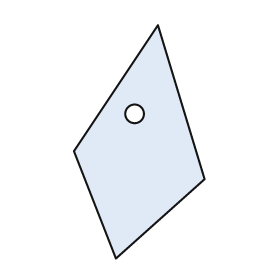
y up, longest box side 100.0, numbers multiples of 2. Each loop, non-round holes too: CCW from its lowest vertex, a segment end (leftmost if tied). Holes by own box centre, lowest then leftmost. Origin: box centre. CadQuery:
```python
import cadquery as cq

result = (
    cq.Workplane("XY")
    .moveTo(-10.0, -50.0)
    .lineTo(28.0, -16.0)
    .lineTo(8.0, 50.0)
    .lineTo(-28.0, -4.0)
    .close()
    .moveTo(-2.0, 12.0)
    .circle(4.0)
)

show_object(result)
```